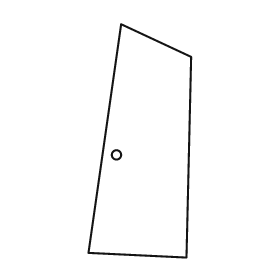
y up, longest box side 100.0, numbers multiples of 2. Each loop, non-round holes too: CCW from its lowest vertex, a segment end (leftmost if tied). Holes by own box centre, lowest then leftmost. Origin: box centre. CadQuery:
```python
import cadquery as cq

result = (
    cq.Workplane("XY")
    .moveTo(20.0, -50.0)
    .lineTo(22.0, 36.0)
    .lineTo(-8.0, 50.0)
    .lineTo(-22.0, -48.0)
    .close()
    .moveTo(-10.0, -6.0)
    .circle(2.0)
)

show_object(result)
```